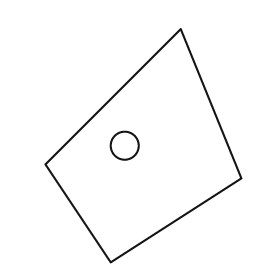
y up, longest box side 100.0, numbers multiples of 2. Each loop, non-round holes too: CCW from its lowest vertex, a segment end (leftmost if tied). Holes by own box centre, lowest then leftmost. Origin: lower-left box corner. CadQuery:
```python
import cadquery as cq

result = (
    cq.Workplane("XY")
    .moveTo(28.0, 0.0)
    .lineTo(84.0, 36.0)
    .lineTo(58.0, 100.0)
    .lineTo(0.0, 42.0)
    .close()
    .moveTo(34.0, 50.0)
    .circle(6.0)
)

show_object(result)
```